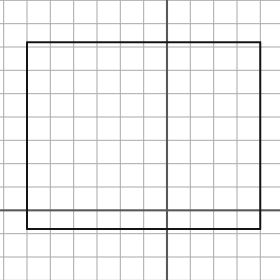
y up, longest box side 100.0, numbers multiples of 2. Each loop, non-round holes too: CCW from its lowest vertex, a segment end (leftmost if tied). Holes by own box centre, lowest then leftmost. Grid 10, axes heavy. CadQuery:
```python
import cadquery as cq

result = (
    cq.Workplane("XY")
    .moveTo(-60.0, -8.0)
    .lineTo(40.0, -8.0)
    .lineTo(40.0, 72.0)
    .lineTo(-60.0, 72.0)
    .close()
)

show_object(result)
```